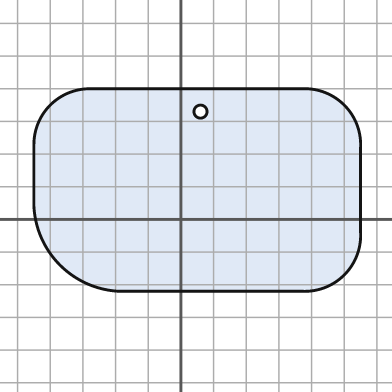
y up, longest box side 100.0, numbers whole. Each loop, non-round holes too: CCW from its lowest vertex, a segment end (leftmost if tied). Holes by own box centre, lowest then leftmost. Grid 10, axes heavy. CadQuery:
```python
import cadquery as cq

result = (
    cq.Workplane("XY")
    .moveTo(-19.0, -22.0)
    .lineTo(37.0, -22.0)
    .threePointArc((50.0, -17.0), (55.0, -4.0))
    .lineTo(55.0, 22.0)
    .threePointArc((50.0, 35.0), (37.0, 40.0))
    .lineTo(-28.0, 40.0)
    .threePointArc((-40.0, 35.0), (-45.0, 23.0))
    .lineTo(-45.0, 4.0)
    .threePointArc((-37.0, -14.0), (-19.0, -22.0))
    .close()
    .moveTo(6.0, 33.0)
    .circle(2.0)
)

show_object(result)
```